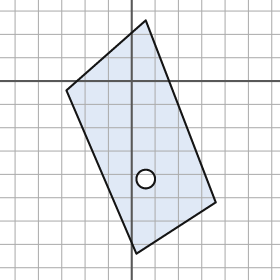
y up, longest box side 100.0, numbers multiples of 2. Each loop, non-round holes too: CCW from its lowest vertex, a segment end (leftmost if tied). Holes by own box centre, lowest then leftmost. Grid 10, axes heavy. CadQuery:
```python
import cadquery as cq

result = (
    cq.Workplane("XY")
    .moveTo(2.0, -74.0)
    .lineTo(36.0, -52.0)
    .lineTo(6.0, 26.0)
    .lineTo(-28.0, -4.0)
    .close()
    .moveTo(6.0, -42.0)
    .circle(4.0)
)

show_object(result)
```